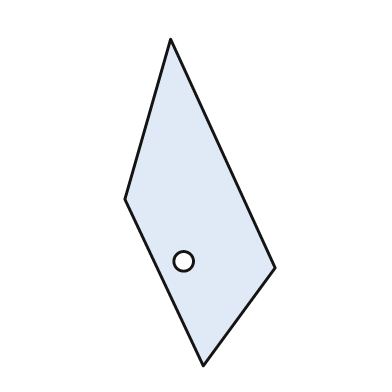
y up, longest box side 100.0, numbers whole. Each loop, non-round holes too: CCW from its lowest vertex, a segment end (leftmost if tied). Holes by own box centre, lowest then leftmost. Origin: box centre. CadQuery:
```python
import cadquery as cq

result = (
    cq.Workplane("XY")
    .moveTo(1.0, -50.0)
    .lineTo(23.0, -20.0)
    .lineTo(-9.0, 50.0)
    .lineTo(-23.0, 1.0)
    .close()
    .moveTo(-5.0, -18.0)
    .circle(3.0)
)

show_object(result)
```